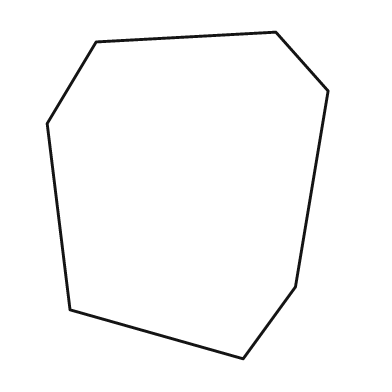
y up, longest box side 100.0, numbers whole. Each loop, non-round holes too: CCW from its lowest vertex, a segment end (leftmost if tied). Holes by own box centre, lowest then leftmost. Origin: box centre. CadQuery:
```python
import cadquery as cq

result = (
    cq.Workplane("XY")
    .moveTo(17.0, -50.0)
    .lineTo(33.0, -28.0)
    .lineTo(43.0, 32.0)
    .lineTo(27.0, 50.0)
    .lineTo(-28.0, 47.0)
    .lineTo(-43.0, 22.0)
    .lineTo(-36.0, -35.0)
    .close()
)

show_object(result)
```